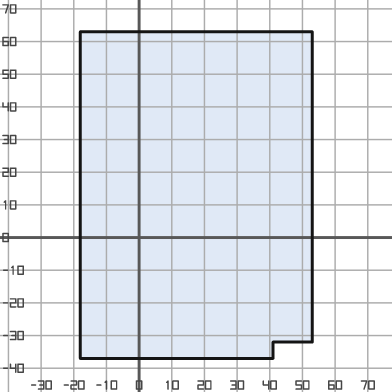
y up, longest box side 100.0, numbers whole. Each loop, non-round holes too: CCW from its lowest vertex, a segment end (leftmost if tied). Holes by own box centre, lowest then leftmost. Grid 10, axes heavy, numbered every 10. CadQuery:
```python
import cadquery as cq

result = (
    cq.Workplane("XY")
    .moveTo(-18.0, -37.0)
    .lineTo(41.0, -37.0)
    .lineTo(41.0, -32.0)
    .lineTo(53.0, -32.0)
    .lineTo(53.0, 63.0)
    .lineTo(-18.0, 63.0)
    .close()
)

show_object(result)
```